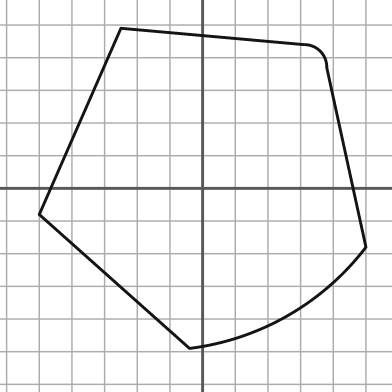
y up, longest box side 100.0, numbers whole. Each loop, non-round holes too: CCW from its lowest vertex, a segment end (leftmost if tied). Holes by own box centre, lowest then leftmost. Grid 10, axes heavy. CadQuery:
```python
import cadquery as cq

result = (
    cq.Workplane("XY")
    .moveTo(-4.0, -49.0)
    .threePointArc((26.0, -39.0), (50.0, -18.0))
    .lineTo(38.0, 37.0)
    .threePointArc((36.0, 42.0), (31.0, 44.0))
    .lineTo(-25.0, 49.0)
    .lineTo(-50.0, -8.0)
    .close()
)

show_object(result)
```